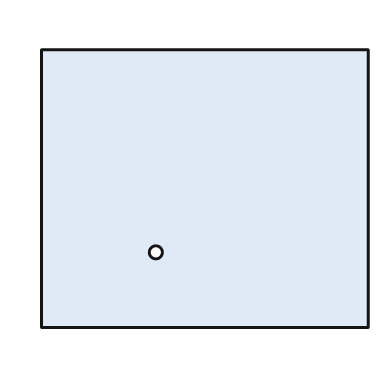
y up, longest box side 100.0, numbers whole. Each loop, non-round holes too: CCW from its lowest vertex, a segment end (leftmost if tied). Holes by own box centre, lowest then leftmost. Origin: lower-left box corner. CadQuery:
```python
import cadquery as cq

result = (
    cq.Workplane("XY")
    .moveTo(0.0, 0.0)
    .lineTo(100.0, 0.0)
    .lineTo(100.0, 85.0)
    .lineTo(0.0, 85.0)
    .close()
    .moveTo(35.0, 23.0)
    .circle(2.0)
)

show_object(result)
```